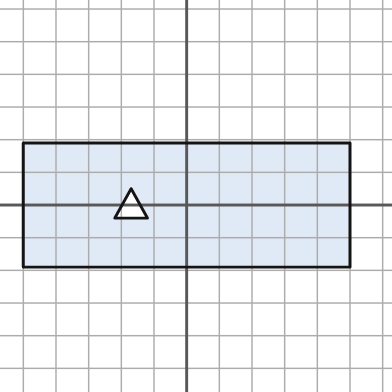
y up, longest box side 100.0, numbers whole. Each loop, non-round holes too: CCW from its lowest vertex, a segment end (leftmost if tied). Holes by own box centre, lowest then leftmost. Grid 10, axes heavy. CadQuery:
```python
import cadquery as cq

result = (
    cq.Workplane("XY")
    .moveTo(-50.0, -19.0)
    .lineTo(50.0, -19.0)
    .lineTo(50.0, 19.0)
    .lineTo(-50.0, 19.0)
    .close()
    .moveTo(-22.0, -4.0)
    .lineTo(-12.0, -4.0)
    .lineTo(-17.0, 5.0)
    .close()
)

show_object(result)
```